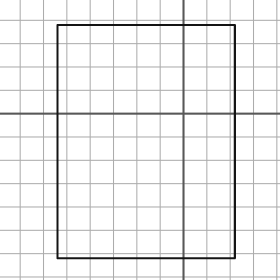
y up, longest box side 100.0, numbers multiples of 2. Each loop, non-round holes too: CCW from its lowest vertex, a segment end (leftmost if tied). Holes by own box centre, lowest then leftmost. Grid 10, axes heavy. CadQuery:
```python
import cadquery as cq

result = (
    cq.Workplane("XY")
    .moveTo(-54.0, -62.0)
    .lineTo(22.0, -62.0)
    .lineTo(22.0, 38.0)
    .lineTo(-54.0, 38.0)
    .close()
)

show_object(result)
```